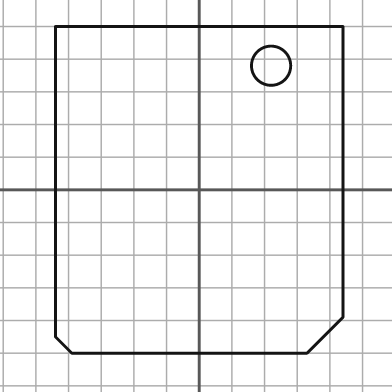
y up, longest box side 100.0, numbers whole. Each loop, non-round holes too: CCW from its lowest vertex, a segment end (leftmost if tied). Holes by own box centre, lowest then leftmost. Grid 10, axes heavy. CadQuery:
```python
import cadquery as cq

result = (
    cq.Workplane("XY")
    .moveTo(-39.0, -50.0)
    .lineTo(33.0, -50.0)
    .lineTo(44.0, -39.0)
    .lineTo(44.0, 50.0)
    .lineTo(-44.0, 50.0)
    .lineTo(-44.0, -45.0)
    .close()
    .moveTo(22.0, 38.0)
    .circle(6.0)
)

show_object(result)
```